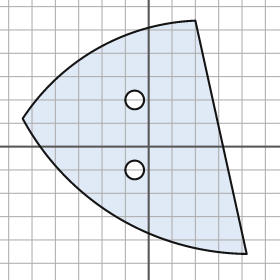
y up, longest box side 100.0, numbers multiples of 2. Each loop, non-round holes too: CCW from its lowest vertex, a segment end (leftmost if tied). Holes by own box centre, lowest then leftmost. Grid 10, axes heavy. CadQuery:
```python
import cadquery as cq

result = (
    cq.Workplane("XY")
    .moveTo(42.0, -46.0)
    .lineTo(20.0, 54.0)
    .threePointArc((-22.0, 42.0), (-54.0, 12.0))
    .threePointArc((-14.0, -30.0), (42.0, -46.0))
    .close()
    .moveTo(-6.0, -10.0)
    .circle(4.0)
    .moveTo(-6.0, 20.0)
    .circle(4.0)
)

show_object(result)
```